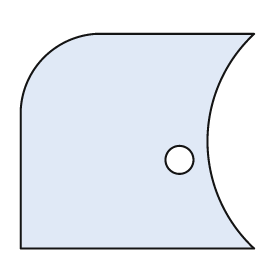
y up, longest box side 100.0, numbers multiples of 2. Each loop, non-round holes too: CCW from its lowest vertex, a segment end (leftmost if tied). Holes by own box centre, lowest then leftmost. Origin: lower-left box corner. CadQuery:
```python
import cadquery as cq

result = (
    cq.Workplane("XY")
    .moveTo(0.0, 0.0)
    .lineTo(100.0, 0.0)
    .threePointArc((80.0, 46.0), (100.0, 92.0))
    .lineTo(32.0, 92.0)
    .threePointArc((10.0, 82.0), (0.0, 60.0))
    .close()
    .moveTo(68.0, 38.0)
    .circle(6.0)
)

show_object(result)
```